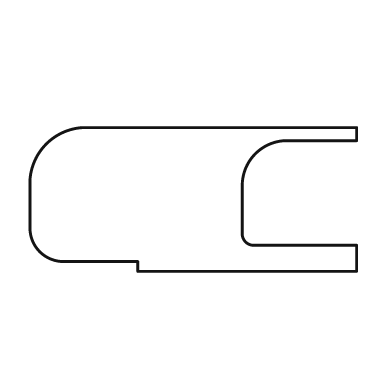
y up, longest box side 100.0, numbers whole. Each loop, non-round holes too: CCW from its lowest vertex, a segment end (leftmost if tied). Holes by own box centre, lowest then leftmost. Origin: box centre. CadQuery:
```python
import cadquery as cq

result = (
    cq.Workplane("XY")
    .moveTo(-17.0, -22.0)
    .lineTo(50.0, -22.0)
    .lineTo(50.0, -14.0)
    .lineTo(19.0, -14.0)
    .threePointArc((16.0, -13.0), (15.0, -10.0))
    .lineTo(15.0, 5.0)
    .threePointArc((19.0, 14.0), (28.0, 18.0))
    .lineTo(50.0, 18.0)
    .lineTo(50.0, 22.0)
    .lineTo(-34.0, 22.0)
    .threePointArc((-45.0, 17.0), (-50.0, 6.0))
    .lineTo(-50.0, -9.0)
    .threePointArc((-47.0, -16.0), (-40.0, -19.0))
    .lineTo(-17.0, -19.0)
    .close()
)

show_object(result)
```